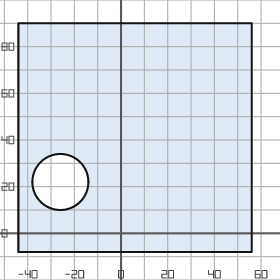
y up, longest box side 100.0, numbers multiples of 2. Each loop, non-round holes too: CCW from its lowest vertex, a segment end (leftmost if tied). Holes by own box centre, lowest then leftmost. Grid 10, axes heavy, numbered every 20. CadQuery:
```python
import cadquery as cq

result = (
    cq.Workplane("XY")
    .moveTo(-44.0, -8.0)
    .lineTo(56.0, -8.0)
    .lineTo(56.0, 90.0)
    .lineTo(-44.0, 90.0)
    .close()
    .moveTo(-26.0, 22.0)
    .circle(12.0)
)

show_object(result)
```